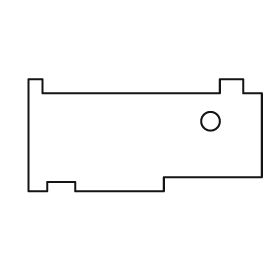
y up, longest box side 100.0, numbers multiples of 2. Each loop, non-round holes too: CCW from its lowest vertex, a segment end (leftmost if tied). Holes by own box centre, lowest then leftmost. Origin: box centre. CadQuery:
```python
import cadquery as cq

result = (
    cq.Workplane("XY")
    .moveTo(-50.0, -24.0)
    .lineTo(-42.0, -24.0)
    .lineTo(-42.0, -20.0)
    .lineTo(-30.0, -20.0)
    .lineTo(-30.0, -24.0)
    .lineTo(8.0, -24.0)
    .lineTo(8.0, -18.0)
    .lineTo(50.0, -18.0)
    .lineTo(50.0, 18.0)
    .lineTo(42.0, 18.0)
    .lineTo(42.0, 24.0)
    .lineTo(32.0, 24.0)
    .lineTo(32.0, 18.0)
    .lineTo(-44.0, 18.0)
    .lineTo(-44.0, 24.0)
    .lineTo(-50.0, 24.0)
    .close()
    .moveTo(28.0, 6.0)
    .circle(4.0)
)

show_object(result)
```